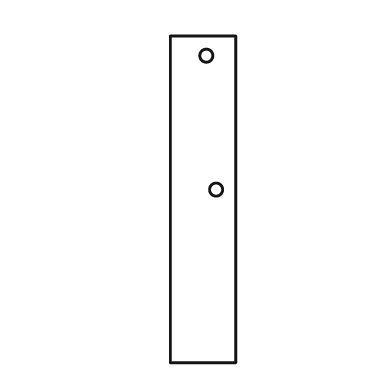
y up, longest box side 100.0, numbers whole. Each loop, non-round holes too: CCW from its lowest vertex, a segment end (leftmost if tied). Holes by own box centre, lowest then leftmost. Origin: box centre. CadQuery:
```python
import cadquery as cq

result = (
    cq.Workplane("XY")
    .moveTo(-10.0, -50.0)
    .lineTo(10.0, -50.0)
    .lineTo(10.0, 50.0)
    .lineTo(-10.0, 50.0)
    .close()
    .moveTo(4.0, 3.0)
    .circle(2.0)
    .moveTo(1.0, 44.0)
    .circle(2.0)
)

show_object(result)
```